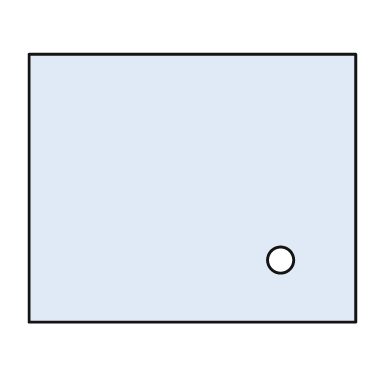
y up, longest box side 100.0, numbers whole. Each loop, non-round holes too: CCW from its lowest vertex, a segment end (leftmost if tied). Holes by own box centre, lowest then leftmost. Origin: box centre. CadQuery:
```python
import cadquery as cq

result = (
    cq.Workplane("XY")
    .moveTo(-50.0, -41.0)
    .lineTo(50.0, -41.0)
    .lineTo(50.0, 41.0)
    .lineTo(-50.0, 41.0)
    .close()
    .moveTo(27.0, -22.0)
    .circle(4.0)
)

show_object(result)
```